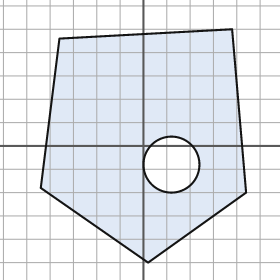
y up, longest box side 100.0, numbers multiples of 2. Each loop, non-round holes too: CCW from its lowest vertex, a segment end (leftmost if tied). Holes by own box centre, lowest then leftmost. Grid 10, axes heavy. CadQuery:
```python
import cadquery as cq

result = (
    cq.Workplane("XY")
    .moveTo(2.0, -50.0)
    .lineTo(44.0, -20.0)
    .lineTo(38.0, 50.0)
    .lineTo(-36.0, 46.0)
    .lineTo(-44.0, -18.0)
    .close()
    .moveTo(12.0, -8.0)
    .circle(12.0)
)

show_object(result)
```